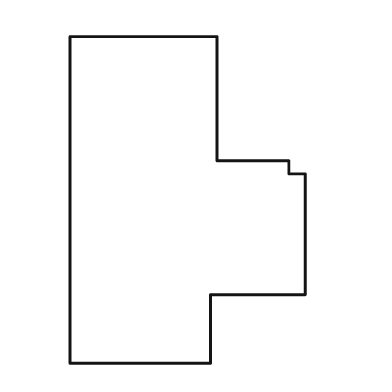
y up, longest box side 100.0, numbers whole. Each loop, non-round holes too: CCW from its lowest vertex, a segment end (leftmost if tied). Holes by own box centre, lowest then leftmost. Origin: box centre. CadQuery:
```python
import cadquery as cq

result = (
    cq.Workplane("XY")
    .moveTo(-36.0, -50.0)
    .lineTo(7.0, -50.0)
    .lineTo(7.0, -29.0)
    .lineTo(36.0, -29.0)
    .lineTo(36.0, 8.0)
    .lineTo(31.0, 8.0)
    .lineTo(31.0, 12.0)
    .lineTo(9.0, 12.0)
    .lineTo(9.0, 50.0)
    .lineTo(-36.0, 50.0)
    .close()
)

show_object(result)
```